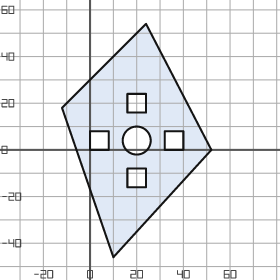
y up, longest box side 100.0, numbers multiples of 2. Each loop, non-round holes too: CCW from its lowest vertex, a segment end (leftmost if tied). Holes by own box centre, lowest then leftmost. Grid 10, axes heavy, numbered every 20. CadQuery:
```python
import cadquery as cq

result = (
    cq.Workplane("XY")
    .moveTo(10.0, -46.0)
    .lineTo(52.0, 0.0)
    .lineTo(24.0, 54.0)
    .lineTo(-12.0, 18.0)
    .close()
    .moveTo(16.0, -16.0)
    .lineTo(24.0, -16.0)
    .lineTo(24.0, -8.0)
    .lineTo(16.0, -8.0)
    .close()
    .moveTo(0.0, 0.0)
    .lineTo(8.0, 0.0)
    .lineTo(8.0, 8.0)
    .lineTo(0.0, 8.0)
    .close()
    .moveTo(20.0, 4.0)
    .circle(6.0)
    .moveTo(32.0, 0.0)
    .lineTo(40.0, 0.0)
    .lineTo(40.0, 8.0)
    .lineTo(32.0, 8.0)
    .close()
    .moveTo(16.0, 16.0)
    .lineTo(24.0, 16.0)
    .lineTo(24.0, 24.0)
    .lineTo(16.0, 24.0)
    .close()
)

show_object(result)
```